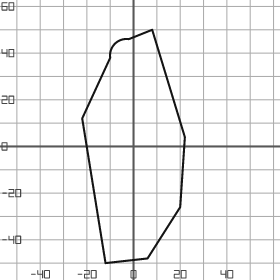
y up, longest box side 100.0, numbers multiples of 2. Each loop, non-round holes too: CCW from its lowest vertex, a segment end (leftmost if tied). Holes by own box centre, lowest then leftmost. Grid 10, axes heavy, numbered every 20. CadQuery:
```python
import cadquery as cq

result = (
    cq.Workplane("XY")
    .moveTo(-12.0, -50.0)
    .lineTo(6.0, -48.0)
    .lineTo(20.0, -26.0)
    .lineTo(22.0, 4.0)
    .lineTo(8.0, 50.0)
    .lineTo(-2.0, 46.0)
    .threePointArc((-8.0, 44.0), (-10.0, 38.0))
    .lineTo(-22.0, 12.0)
    .close()
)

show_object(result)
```